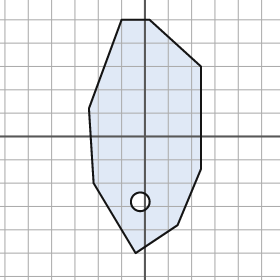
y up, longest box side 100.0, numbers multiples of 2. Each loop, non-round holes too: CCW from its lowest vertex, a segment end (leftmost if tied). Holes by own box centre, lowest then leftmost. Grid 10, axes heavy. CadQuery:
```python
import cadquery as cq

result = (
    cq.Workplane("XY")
    .moveTo(-4.0, -50.0)
    .lineTo(14.0, -38.0)
    .lineTo(24.0, -14.0)
    .lineTo(24.0, 30.0)
    .lineTo(2.0, 50.0)
    .lineTo(-10.0, 50.0)
    .lineTo(-24.0, 12.0)
    .lineTo(-22.0, -20.0)
    .close()
    .moveTo(-2.0, -28.0)
    .circle(4.0)
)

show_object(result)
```